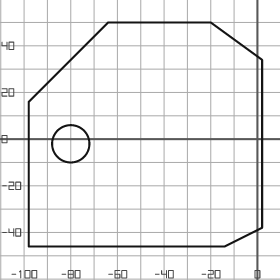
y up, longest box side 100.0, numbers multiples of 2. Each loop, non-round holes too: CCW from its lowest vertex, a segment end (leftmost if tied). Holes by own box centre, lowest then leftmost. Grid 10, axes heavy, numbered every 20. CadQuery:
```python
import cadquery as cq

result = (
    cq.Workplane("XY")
    .moveTo(-98.0, -46.0)
    .lineTo(-14.0, -46.0)
    .lineTo(2.0, -38.0)
    .lineTo(2.0, 34.0)
    .lineTo(-20.0, 50.0)
    .lineTo(-64.0, 50.0)
    .lineTo(-98.0, 16.0)
    .close()
    .moveTo(-80.0, -2.0)
    .circle(8.0)
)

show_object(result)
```